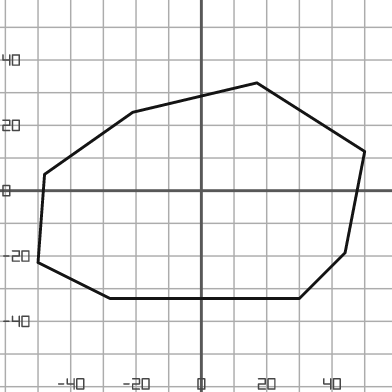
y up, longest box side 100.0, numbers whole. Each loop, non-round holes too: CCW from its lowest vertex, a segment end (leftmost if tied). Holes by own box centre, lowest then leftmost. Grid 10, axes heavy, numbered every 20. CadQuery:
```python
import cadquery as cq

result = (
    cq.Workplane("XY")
    .moveTo(-28.0, -33.0)
    .lineTo(30.0, -33.0)
    .lineTo(44.0, -19.0)
    .lineTo(50.0, 12.0)
    .lineTo(17.0, 33.0)
    .lineTo(-21.0, 24.0)
    .lineTo(-48.0, 5.0)
    .lineTo(-50.0, -22.0)
    .close()
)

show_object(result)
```